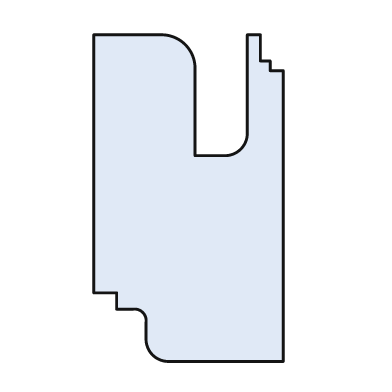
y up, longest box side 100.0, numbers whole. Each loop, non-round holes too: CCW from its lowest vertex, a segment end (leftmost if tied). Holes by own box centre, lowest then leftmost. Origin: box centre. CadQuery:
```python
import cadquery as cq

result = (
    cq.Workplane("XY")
    .moveTo(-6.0, -50.0)
    .lineTo(29.0, -50.0)
    .lineTo(29.0, 39.0)
    .lineTo(25.0, 39.0)
    .lineTo(25.0, 42.0)
    .lineTo(22.0, 42.0)
    .lineTo(22.0, 50.0)
    .lineTo(18.0, 50.0)
    .lineTo(18.0, 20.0)
    .threePointArc((16.0, 15.0), (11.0, 13.0))
    .lineTo(2.0, 13.0)
    .lineTo(2.0, 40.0)
    .threePointArc((-1.0, 47.0), (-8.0, 50.0))
    .lineTo(-29.0, 50.0)
    .lineTo(-29.0, -29.0)
    .lineTo(-22.0, -29.0)
    .lineTo(-22.0, -34.0)
    .lineTo(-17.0, -34.0)
    .threePointArc((-14.0, -35.0), (-13.0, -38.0))
    .lineTo(-13.0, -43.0)
    .threePointArc((-11.0, -48.0), (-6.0, -50.0))
    .close()
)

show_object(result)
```